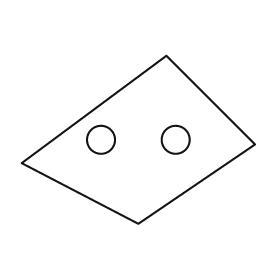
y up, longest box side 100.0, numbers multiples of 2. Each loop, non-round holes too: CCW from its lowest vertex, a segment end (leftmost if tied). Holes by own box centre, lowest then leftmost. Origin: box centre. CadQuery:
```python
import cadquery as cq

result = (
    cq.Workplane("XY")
    .moveTo(0.0, -36.0)
    .lineTo(50.0, -2.0)
    .lineTo(12.0, 36.0)
    .lineTo(-50.0, -10.0)
    .close()
    .moveTo(-16.0, 0.0)
    .circle(6.0)
    .moveTo(16.0, 0.0)
    .circle(6.0)
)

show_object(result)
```